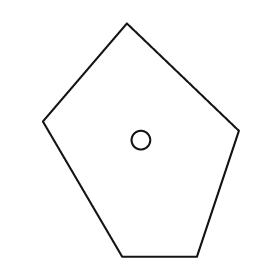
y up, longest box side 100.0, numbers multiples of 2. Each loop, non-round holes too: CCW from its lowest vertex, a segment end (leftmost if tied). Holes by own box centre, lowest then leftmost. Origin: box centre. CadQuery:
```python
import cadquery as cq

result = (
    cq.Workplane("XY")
    .moveTo(-8.0, -50.0)
    .lineTo(24.0, -50.0)
    .lineTo(42.0, 4.0)
    .lineTo(-6.0, 50.0)
    .lineTo(-42.0, 8.0)
    .close()
    .moveTo(0.0, 0.0)
    .circle(4.0)
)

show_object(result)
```